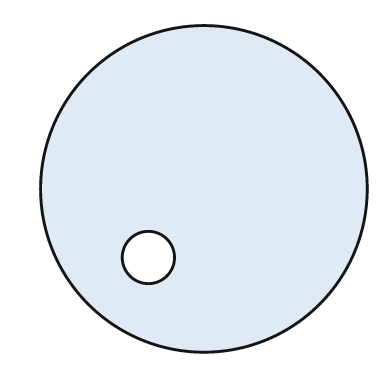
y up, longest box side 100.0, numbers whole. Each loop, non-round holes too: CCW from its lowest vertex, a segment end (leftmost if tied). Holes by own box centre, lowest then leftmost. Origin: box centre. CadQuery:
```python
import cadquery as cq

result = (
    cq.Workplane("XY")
    .moveTo(0.0, 0.0)
    .circle(50.0)
    .moveTo(-17.0, -21.0)
    .circle(8.0)
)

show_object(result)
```